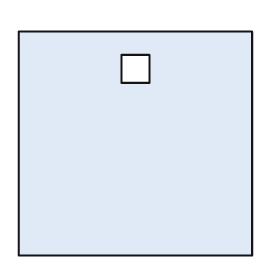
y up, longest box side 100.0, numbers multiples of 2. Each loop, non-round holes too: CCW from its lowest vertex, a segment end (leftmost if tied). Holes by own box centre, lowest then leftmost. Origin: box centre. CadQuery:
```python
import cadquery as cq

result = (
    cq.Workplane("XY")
    .moveTo(-50.0, -48.0)
    .lineTo(50.0, -48.0)
    .lineTo(50.0, 48.0)
    .lineTo(-50.0, 48.0)
    .close()
    .moveTo(-6.0, 26.0)
    .lineTo(6.0, 26.0)
    .lineTo(6.0, 38.0)
    .lineTo(-6.0, 38.0)
    .close()
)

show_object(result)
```